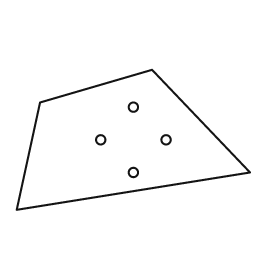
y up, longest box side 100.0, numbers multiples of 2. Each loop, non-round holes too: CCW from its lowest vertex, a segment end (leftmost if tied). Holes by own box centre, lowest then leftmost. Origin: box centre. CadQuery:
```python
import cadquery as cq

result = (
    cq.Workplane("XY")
    .moveTo(-50.0, -30.0)
    .lineTo(50.0, -14.0)
    .lineTo(8.0, 30.0)
    .lineTo(-40.0, 16.0)
    .close()
    .moveTo(0.0, -14.0)
    .circle(2.0)
    .moveTo(-14.0, 0.0)
    .circle(2.0)
    .moveTo(14.0, 0.0)
    .circle(2.0)
    .moveTo(0.0, 14.0)
    .circle(2.0)
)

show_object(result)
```